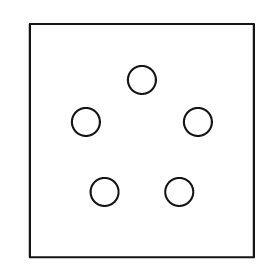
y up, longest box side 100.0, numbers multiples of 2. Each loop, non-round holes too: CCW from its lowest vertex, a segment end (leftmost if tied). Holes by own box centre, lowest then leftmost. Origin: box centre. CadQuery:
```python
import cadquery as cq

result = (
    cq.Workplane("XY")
    .moveTo(-48.0, -50.0)
    .lineTo(48.0, -50.0)
    .lineTo(48.0, 50.0)
    .lineTo(-48.0, 50.0)
    .close()
    .moveTo(-16.0, -22.0)
    .circle(6.0)
    .moveTo(16.0, -22.0)
    .circle(6.0)
    .moveTo(-24.0, 8.0)
    .circle(6.0)
    .moveTo(24.0, 8.0)
    .circle(6.0)
    .moveTo(0.0, 26.0)
    .circle(6.0)
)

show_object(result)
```